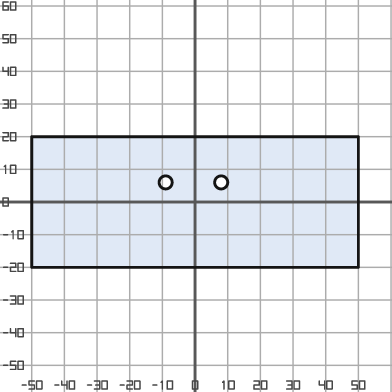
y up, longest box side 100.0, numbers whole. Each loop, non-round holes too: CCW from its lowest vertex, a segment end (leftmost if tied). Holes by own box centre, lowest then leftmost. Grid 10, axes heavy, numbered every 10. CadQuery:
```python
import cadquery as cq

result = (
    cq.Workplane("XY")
    .moveTo(-50.0, -20.0)
    .lineTo(50.0, -20.0)
    .lineTo(50.0, 20.0)
    .lineTo(-50.0, 20.0)
    .close()
    .moveTo(-9.0, 6.0)
    .circle(2.0)
    .moveTo(8.0, 6.0)
    .circle(2.0)
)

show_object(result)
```